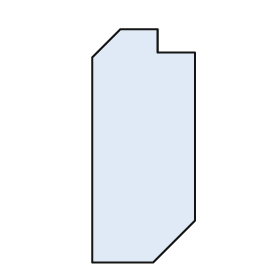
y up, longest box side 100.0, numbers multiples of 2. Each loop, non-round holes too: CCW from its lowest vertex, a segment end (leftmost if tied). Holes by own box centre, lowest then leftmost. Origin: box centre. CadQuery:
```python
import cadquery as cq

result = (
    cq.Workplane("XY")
    .moveTo(-22.0, -50.0)
    .lineTo(4.0, -50.0)
    .lineTo(22.0, -32.0)
    .lineTo(22.0, 40.0)
    .lineTo(6.0, 40.0)
    .lineTo(6.0, 50.0)
    .lineTo(-10.0, 50.0)
    .lineTo(-22.0, 38.0)
    .close()
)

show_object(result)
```